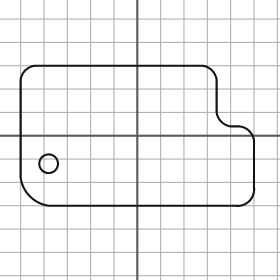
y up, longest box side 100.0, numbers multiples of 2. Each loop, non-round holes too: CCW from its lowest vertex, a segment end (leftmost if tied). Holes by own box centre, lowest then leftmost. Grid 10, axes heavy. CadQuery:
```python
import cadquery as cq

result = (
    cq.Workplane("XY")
    .moveTo(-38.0, -30.0)
    .lineTo(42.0, -30.0)
    .threePointArc((48.0, -28.0), (50.0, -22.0))
    .lineTo(50.0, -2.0)
    .threePointArc((48.0, 2.0), (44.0, 4.0))
    .lineTo(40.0, 4.0)
    .threePointArc((36.0, 6.0), (34.0, 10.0))
    .lineTo(34.0, 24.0)
    .threePointArc((32.0, 28.0), (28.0, 30.0))
    .lineTo(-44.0, 30.0)
    .threePointArc((-48.0, 28.0), (-50.0, 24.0))
    .lineTo(-50.0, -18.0)
    .threePointArc((-46.0, -26.0), (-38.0, -30.0))
    .close()
    .moveTo(-38.0, -12.0)
    .circle(4.0)
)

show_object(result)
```